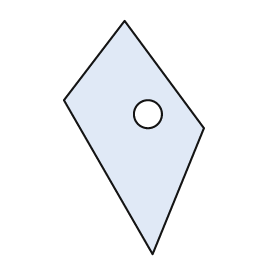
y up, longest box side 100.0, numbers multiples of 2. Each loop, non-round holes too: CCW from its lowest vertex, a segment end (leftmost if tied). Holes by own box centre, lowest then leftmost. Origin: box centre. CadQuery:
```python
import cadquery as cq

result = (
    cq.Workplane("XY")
    .moveTo(8.0, -50.0)
    .lineTo(30.0, 4.0)
    .lineTo(-4.0, 50.0)
    .lineTo(-30.0, 16.0)
    .close()
    .moveTo(6.0, 10.0)
    .circle(6.0)
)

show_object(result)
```